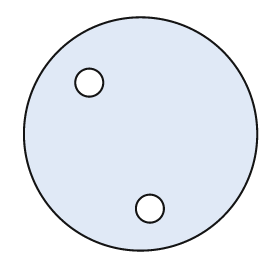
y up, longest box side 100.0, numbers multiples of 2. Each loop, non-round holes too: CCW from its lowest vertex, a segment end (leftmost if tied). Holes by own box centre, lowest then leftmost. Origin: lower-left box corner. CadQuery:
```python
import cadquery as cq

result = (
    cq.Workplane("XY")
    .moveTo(50.0, 50.0)
    .circle(50.0)
    .moveTo(54.0, 18.0)
    .circle(6.0)
    .moveTo(28.0, 72.0)
    .circle(6.0)
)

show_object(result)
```